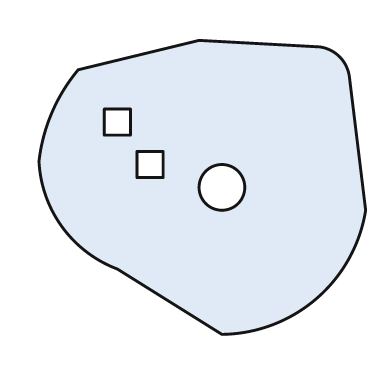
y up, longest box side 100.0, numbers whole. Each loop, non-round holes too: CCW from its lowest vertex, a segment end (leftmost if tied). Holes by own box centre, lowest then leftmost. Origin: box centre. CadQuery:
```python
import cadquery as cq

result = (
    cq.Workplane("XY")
    .moveTo(6.0, -45.0)
    .threePointArc((35.0, -34.0), (50.0, -7.0))
    .lineTo(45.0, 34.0)
    .threePointArc((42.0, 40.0), (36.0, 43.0))
    .lineTo(-1.0, 45.0)
    .lineTo(-38.0, 36.0)
    .threePointArc((-46.0, 23.0), (-50.0, 8.0))
    .threePointArc((-43.0, -12.0), (-26.0, -25.0))
    .close()
    .moveTo(6.0, 0.0)
    .circle(7.0)
    .moveTo(-20.0, 3.0)
    .lineTo(-12.0, 3.0)
    .lineTo(-12.0, 11.0)
    .lineTo(-20.0, 11.0)
    .close()
    .moveTo(-30.0, 16.0)
    .lineTo(-22.0, 16.0)
    .lineTo(-22.0, 24.0)
    .lineTo(-30.0, 24.0)
    .close()
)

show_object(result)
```